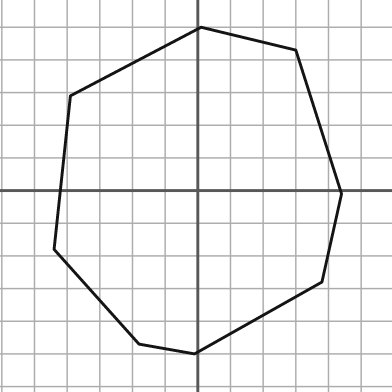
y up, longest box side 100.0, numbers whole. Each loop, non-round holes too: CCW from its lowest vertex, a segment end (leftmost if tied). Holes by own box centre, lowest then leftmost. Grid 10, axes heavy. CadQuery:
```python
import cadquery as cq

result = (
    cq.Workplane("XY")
    .moveTo(-1.0, -50.0)
    .lineTo(38.0, -28.0)
    .lineTo(44.0, -1.0)
    .lineTo(30.0, 43.0)
    .lineTo(1.0, 50.0)
    .lineTo(-39.0, 29.0)
    .lineTo(-44.0, -18.0)
    .lineTo(-18.0, -47.0)
    .close()
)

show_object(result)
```